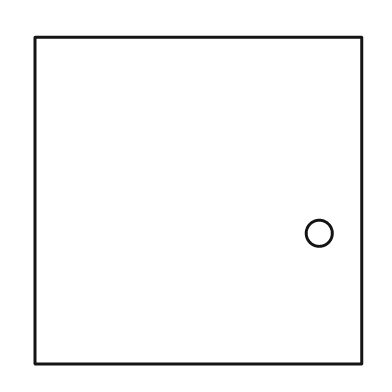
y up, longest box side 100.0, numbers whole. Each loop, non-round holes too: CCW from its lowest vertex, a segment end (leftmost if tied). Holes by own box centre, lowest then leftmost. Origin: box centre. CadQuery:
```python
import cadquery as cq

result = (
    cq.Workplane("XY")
    .moveTo(-50.0, -50.0)
    .lineTo(50.0, -50.0)
    .lineTo(50.0, 50.0)
    .lineTo(-50.0, 50.0)
    .close()
    .moveTo(37.0, -10.0)
    .circle(4.0)
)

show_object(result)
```